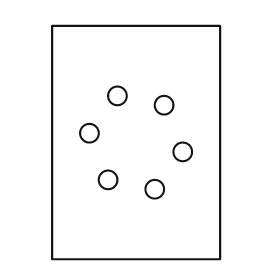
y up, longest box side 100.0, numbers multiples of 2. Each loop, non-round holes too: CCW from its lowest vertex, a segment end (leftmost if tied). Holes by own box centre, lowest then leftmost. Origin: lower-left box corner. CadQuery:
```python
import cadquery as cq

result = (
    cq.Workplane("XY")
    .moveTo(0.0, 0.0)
    .lineTo(72.0, 0.0)
    .lineTo(72.0, 100.0)
    .lineTo(0.0, 100.0)
    .close()
    .moveTo(44.0, 30.0)
    .circle(4.0)
    .moveTo(24.0, 34.0)
    .circle(4.0)
    .moveTo(56.0, 46.0)
    .circle(4.0)
    .moveTo(16.0, 54.0)
    .circle(4.0)
    .moveTo(48.0, 66.0)
    .circle(4.0)
    .moveTo(28.0, 70.0)
    .circle(4.0)
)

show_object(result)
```